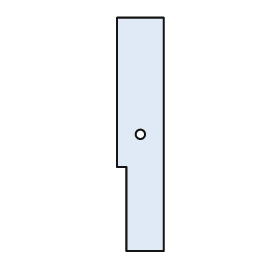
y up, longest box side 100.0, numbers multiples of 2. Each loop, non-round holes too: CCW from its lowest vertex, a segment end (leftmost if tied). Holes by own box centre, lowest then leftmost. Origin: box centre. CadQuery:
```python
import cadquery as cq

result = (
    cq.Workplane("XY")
    .moveTo(-6.0, -50.0)
    .lineTo(10.0, -50.0)
    .lineTo(10.0, 50.0)
    .lineTo(-10.0, 50.0)
    .lineTo(-10.0, -14.0)
    .lineTo(-6.0, -14.0)
    .close()
    .moveTo(0.0, 0.0)
    .circle(2.0)
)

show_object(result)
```